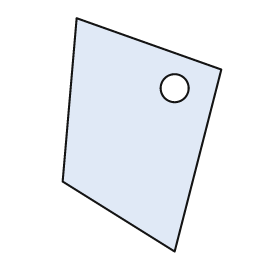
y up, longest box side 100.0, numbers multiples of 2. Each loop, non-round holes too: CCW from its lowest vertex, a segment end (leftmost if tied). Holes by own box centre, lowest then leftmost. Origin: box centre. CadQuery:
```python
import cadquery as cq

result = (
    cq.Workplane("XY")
    .moveTo(14.0, -50.0)
    .lineTo(34.0, 28.0)
    .lineTo(-28.0, 50.0)
    .lineTo(-34.0, -20.0)
    .close()
    .moveTo(14.0, 20.0)
    .circle(6.0)
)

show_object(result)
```